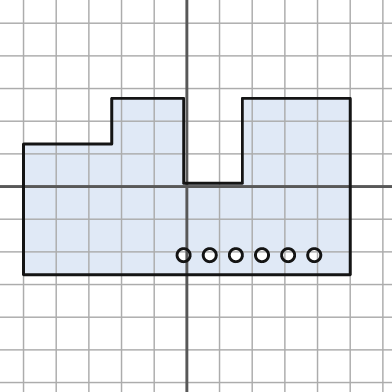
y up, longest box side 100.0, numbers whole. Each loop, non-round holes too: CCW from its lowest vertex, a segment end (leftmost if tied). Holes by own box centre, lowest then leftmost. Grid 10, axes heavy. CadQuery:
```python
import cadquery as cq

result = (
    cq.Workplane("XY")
    .moveTo(-50.0, -27.0)
    .lineTo(50.0, -27.0)
    .lineTo(50.0, 27.0)
    .lineTo(17.0, 27.0)
    .lineTo(17.0, 1.0)
    .lineTo(-1.0, 1.0)
    .lineTo(-1.0, 27.0)
    .lineTo(-23.0, 27.0)
    .lineTo(-23.0, 13.0)
    .lineTo(-50.0, 13.0)
    .close()
    .moveTo(-1.0, -21.0)
    .circle(2.0)
    .moveTo(7.0, -21.0)
    .circle(2.0)
    .moveTo(15.0, -21.0)
    .circle(2.0)
    .moveTo(23.0, -21.0)
    .circle(2.0)
    .moveTo(31.0, -21.0)
    .circle(2.0)
    .moveTo(39.0, -21.0)
    .circle(2.0)
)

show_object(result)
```